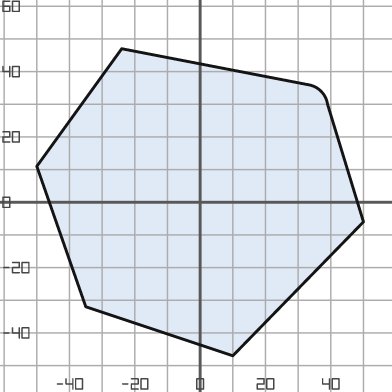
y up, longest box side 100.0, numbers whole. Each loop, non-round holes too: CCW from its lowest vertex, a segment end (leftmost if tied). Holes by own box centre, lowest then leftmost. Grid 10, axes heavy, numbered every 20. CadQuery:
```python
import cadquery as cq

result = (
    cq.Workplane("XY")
    .moveTo(10.0, -47.0)
    .lineTo(50.0, -6.0)
    .lineTo(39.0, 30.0)
    .threePointArc((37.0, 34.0), (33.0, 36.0))
    .lineTo(-24.0, 47.0)
    .lineTo(-50.0, 11.0)
    .lineTo(-35.0, -32.0)
    .close()
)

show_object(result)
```